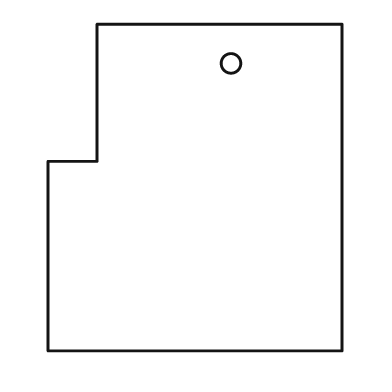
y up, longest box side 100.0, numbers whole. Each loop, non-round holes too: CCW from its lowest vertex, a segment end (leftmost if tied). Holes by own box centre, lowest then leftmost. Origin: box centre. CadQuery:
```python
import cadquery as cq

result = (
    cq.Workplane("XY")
    .moveTo(-45.0, -50.0)
    .lineTo(45.0, -50.0)
    .lineTo(45.0, 50.0)
    .lineTo(-30.0, 50.0)
    .lineTo(-30.0, 8.0)
    .lineTo(-45.0, 8.0)
    .close()
    .moveTo(11.0, 38.0)
    .circle(3.0)
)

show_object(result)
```